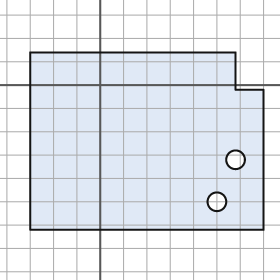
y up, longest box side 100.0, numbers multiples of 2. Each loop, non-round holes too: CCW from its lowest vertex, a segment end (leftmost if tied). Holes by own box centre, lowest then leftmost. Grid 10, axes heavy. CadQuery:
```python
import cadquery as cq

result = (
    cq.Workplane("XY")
    .moveTo(-30.0, -62.0)
    .lineTo(70.0, -62.0)
    .lineTo(70.0, -2.0)
    .lineTo(58.0, -2.0)
    .lineTo(58.0, 14.0)
    .lineTo(-30.0, 14.0)
    .close()
    .moveTo(50.0, -50.0)
    .circle(4.0)
    .moveTo(58.0, -32.0)
    .circle(4.0)
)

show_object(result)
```